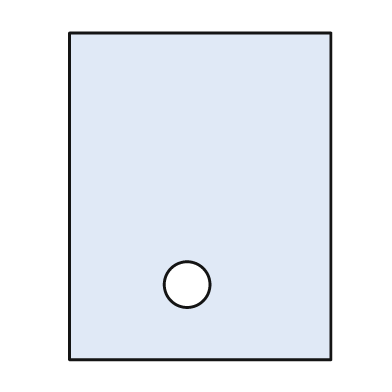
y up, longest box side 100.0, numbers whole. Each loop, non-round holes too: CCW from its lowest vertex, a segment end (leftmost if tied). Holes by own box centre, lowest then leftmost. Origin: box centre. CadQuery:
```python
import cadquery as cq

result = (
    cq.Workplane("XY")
    .moveTo(-40.0, -50.0)
    .lineTo(40.0, -50.0)
    .lineTo(40.0, 50.0)
    .lineTo(-40.0, 50.0)
    .close()
    .moveTo(-4.0, -27.0)
    .circle(7.0)
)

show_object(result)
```